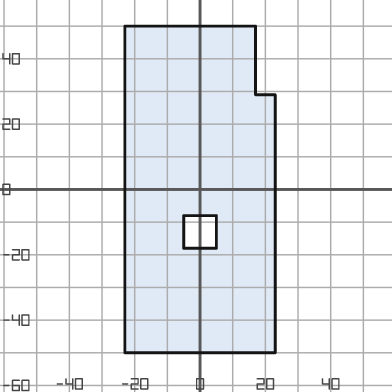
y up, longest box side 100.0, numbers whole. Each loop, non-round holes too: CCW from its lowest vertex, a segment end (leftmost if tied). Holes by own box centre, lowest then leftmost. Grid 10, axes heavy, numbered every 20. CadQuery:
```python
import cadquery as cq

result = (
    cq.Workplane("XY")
    .moveTo(-23.0, -50.0)
    .lineTo(23.0, -50.0)
    .lineTo(23.0, 29.0)
    .lineTo(17.0, 29.0)
    .lineTo(17.0, 50.0)
    .lineTo(-23.0, 50.0)
    .close()
    .moveTo(-5.0, -18.0)
    .lineTo(5.0, -18.0)
    .lineTo(5.0, -8.0)
    .lineTo(-5.0, -8.0)
    .close()
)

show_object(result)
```